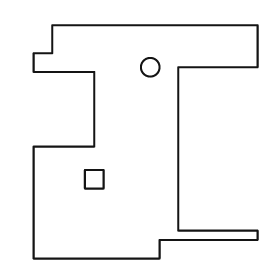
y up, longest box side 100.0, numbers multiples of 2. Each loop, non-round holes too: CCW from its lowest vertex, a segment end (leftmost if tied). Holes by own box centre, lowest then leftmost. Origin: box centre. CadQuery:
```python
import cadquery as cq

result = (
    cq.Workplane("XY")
    .moveTo(-48.0, -50.0)
    .lineTo(6.0, -50.0)
    .lineTo(6.0, -42.0)
    .lineTo(48.0, -42.0)
    .lineTo(48.0, -38.0)
    .lineTo(14.0, -38.0)
    .lineTo(14.0, 32.0)
    .lineTo(48.0, 32.0)
    .lineTo(48.0, 50.0)
    .lineTo(-40.0, 50.0)
    .lineTo(-40.0, 38.0)
    .lineTo(-48.0, 38.0)
    .lineTo(-48.0, 30.0)
    .lineTo(-22.0, 30.0)
    .lineTo(-22.0, -2.0)
    .lineTo(-48.0, -2.0)
    .close()
    .moveTo(-26.0, -20.0)
    .lineTo(-18.0, -20.0)
    .lineTo(-18.0, -12.0)
    .lineTo(-26.0, -12.0)
    .close()
    .moveTo(2.0, 32.0)
    .circle(4.0)
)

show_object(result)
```